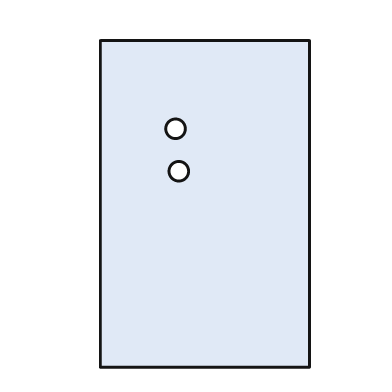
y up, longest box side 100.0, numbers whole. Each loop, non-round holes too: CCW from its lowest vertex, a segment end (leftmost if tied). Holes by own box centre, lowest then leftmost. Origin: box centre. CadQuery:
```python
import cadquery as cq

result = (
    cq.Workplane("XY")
    .moveTo(-32.0, -50.0)
    .lineTo(32.0, -50.0)
    .lineTo(32.0, 50.0)
    .lineTo(-32.0, 50.0)
    .close()
    .moveTo(-8.0, 10.0)
    .circle(3.0)
    .moveTo(-9.0, 23.0)
    .circle(3.0)
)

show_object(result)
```